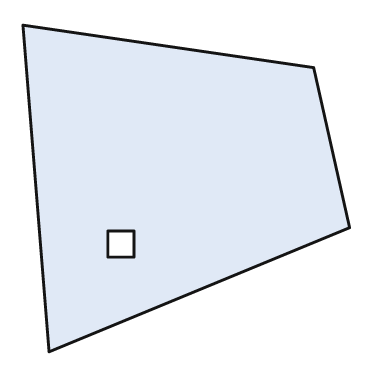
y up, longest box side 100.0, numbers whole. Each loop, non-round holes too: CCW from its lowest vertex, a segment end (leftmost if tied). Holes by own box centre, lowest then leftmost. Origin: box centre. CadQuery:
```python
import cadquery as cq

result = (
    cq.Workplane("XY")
    .moveTo(-42.0, -50.0)
    .lineTo(50.0, -12.0)
    .lineTo(39.0, 37.0)
    .lineTo(-50.0, 50.0)
    .close()
    .moveTo(-24.0, -21.0)
    .lineTo(-16.0, -21.0)
    .lineTo(-16.0, -13.0)
    .lineTo(-24.0, -13.0)
    .close()
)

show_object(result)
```